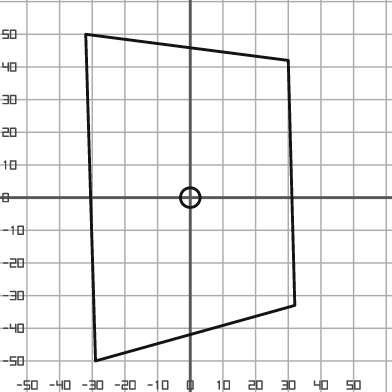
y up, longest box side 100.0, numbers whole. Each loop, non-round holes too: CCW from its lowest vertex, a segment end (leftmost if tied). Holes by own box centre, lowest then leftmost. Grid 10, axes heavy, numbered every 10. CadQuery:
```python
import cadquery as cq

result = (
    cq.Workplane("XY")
    .moveTo(-29.0, -50.0)
    .lineTo(32.0, -33.0)
    .lineTo(30.0, 42.0)
    .lineTo(-32.0, 50.0)
    .close()
    .moveTo(0.0, 0.0)
    .circle(3.0)
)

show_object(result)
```